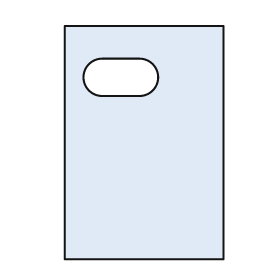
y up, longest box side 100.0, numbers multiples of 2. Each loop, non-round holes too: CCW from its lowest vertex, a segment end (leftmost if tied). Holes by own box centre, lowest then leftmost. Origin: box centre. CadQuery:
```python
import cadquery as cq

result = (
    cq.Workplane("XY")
    .moveTo(-34.0, -50.0)
    .lineTo(34.0, -50.0)
    .lineTo(34.0, 50.0)
    .lineTo(-34.0, 50.0)
    .close()
    .moveTo(-18.0, 20.0)
    .lineTo(-2.0, 20.0)
    .threePointArc((6.0, 28.0), (-2.0, 36.0))
    .lineTo(-18.0, 36.0)
    .threePointArc((-26.0, 28.0), (-18.0, 20.0))
    .close()
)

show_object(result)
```